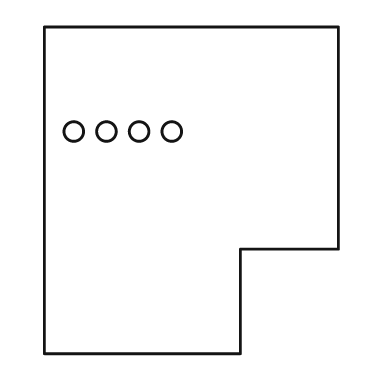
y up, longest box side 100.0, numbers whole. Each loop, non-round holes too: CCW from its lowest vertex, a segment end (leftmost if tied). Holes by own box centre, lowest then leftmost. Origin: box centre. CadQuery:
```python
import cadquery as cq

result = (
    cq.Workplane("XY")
    .moveTo(-45.0, -50.0)
    .lineTo(15.0, -50.0)
    .lineTo(15.0, -18.0)
    .lineTo(45.0, -18.0)
    .lineTo(45.0, 50.0)
    .lineTo(-45.0, 50.0)
    .close()
    .moveTo(-36.0, 18.0)
    .circle(3.0)
    .moveTo(-26.0, 18.0)
    .circle(3.0)
    .moveTo(-16.0, 18.0)
    .circle(3.0)
    .moveTo(-6.0, 18.0)
    .circle(3.0)
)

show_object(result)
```